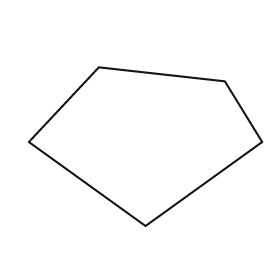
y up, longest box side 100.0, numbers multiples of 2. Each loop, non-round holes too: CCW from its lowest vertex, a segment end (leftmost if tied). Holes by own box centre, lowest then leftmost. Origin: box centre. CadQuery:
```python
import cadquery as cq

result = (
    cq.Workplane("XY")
    .moveTo(0.0, -34.0)
    .lineTo(50.0, 2.0)
    .lineTo(34.0, 28.0)
    .lineTo(-20.0, 34.0)
    .lineTo(-50.0, 2.0)
    .close()
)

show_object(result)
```